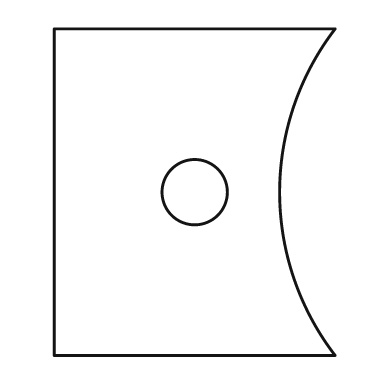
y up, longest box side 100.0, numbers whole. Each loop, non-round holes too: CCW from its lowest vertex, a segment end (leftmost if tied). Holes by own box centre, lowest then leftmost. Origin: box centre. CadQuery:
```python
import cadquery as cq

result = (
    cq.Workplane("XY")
    .moveTo(-43.0, -50.0)
    .lineTo(43.0, -50.0)
    .threePointArc((26.0, 0.0), (43.0, 50.0))
    .lineTo(-43.0, 50.0)
    .close()
    .moveTo(0.0, 0.0)
    .circle(10.0)
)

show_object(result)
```